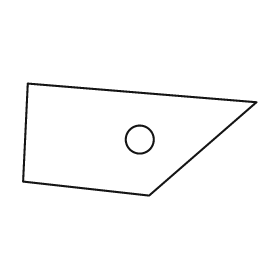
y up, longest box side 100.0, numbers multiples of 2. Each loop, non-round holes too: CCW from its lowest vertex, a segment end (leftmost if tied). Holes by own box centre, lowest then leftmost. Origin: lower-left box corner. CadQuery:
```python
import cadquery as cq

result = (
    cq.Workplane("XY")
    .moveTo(54.0, 0.0)
    .lineTo(100.0, 40.0)
    .lineTo(2.0, 48.0)
    .lineTo(0.0, 6.0)
    .close()
    .moveTo(50.0, 24.0)
    .circle(6.0)
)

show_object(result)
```